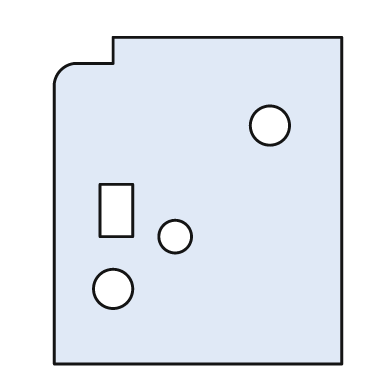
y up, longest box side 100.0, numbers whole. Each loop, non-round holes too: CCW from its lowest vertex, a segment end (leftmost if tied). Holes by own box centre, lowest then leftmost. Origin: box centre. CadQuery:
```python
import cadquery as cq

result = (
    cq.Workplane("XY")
    .moveTo(-44.0, -50.0)
    .lineTo(44.0, -50.0)
    .lineTo(44.0, 50.0)
    .lineTo(-26.0, 50.0)
    .lineTo(-26.0, 42.0)
    .lineTo(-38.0, 42.0)
    .threePointArc((-42.0, 40.0), (-44.0, 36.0))
    .close()
    .moveTo(-26.0, -27.0)
    .circle(6.0)
    .moveTo(-7.0, -11.0)
    .circle(5.0)
    .moveTo(-30.0, -11.0)
    .lineTo(-20.0, -11.0)
    .lineTo(-20.0, 5.0)
    .lineTo(-30.0, 5.0)
    .close()
    .moveTo(22.0, 23.0)
    .circle(6.0)
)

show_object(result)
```